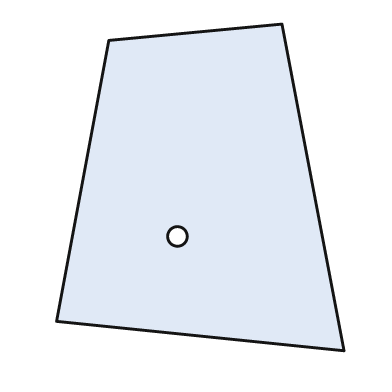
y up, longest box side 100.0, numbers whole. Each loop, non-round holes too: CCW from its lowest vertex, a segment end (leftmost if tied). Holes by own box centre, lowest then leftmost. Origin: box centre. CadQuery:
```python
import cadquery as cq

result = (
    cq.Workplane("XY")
    .moveTo(44.0, -50.0)
    .lineTo(25.0, 50.0)
    .lineTo(-28.0, 45.0)
    .lineTo(-44.0, -41.0)
    .close()
    .moveTo(-7.0, -15.0)
    .circle(3.0)
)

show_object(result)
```